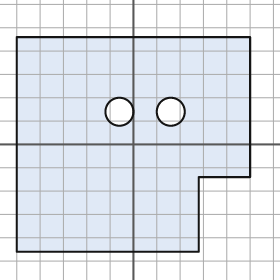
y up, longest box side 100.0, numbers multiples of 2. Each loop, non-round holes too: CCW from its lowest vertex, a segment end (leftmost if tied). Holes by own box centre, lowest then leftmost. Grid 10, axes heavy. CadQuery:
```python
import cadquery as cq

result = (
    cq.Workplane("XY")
    .moveTo(-50.0, -46.0)
    .lineTo(28.0, -46.0)
    .lineTo(28.0, -14.0)
    .lineTo(50.0, -14.0)
    .lineTo(50.0, 46.0)
    .lineTo(-50.0, 46.0)
    .close()
    .moveTo(-6.0, 14.0)
    .circle(6.0)
    .moveTo(16.0, 14.0)
    .circle(6.0)
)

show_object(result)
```